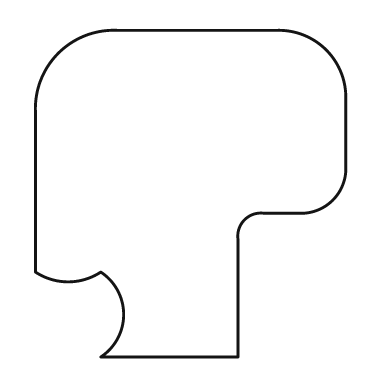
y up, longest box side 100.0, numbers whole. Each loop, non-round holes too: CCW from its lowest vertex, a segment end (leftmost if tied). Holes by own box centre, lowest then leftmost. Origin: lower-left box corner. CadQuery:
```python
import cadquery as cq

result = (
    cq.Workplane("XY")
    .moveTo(20.0, 0.0)
    .lineTo(62.0, 0.0)
    .lineTo(62.0, 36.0)
    .threePointArc((64.0, 42.0), (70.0, 44.0))
    .lineTo(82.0, 44.0)
    .threePointArc((91.0, 48.0), (95.0, 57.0))
    .lineTo(95.0, 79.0)
    .threePointArc((89.0, 94.0), (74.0, 100.0))
    .lineTo(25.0, 100.0)
    .threePointArc((7.0, 93.0), (0.0, 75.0))
    .lineTo(0.0, 26.0)
    .threePointArc((10.0, 23.0), (20.0, 26.0))
    .threePointArc((27.0, 13.0), (20.0, 0.0))
    .close()
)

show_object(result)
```